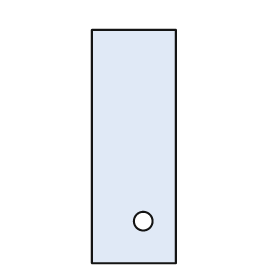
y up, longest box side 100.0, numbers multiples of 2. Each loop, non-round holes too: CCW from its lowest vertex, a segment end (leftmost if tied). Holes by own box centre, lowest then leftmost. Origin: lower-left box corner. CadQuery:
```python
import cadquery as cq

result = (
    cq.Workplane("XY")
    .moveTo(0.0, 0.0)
    .lineTo(36.0, 0.0)
    .lineTo(36.0, 100.0)
    .lineTo(0.0, 100.0)
    .close()
    .moveTo(22.0, 18.0)
    .circle(4.0)
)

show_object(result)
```